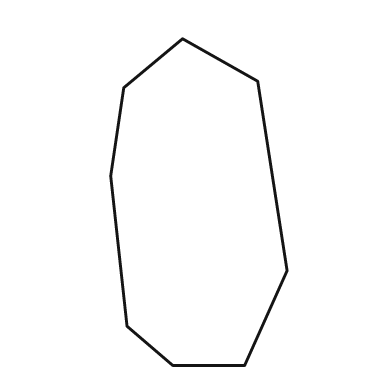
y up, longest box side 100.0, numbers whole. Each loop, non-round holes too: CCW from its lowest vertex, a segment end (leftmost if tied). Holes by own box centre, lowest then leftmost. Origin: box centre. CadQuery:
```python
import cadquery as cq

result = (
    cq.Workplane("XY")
    .moveTo(-8.0, -50.0)
    .lineTo(14.0, -50.0)
    .lineTo(27.0, -21.0)
    .lineTo(18.0, 37.0)
    .lineTo(-5.0, 50.0)
    .lineTo(-23.0, 35.0)
    .lineTo(-27.0, 8.0)
    .lineTo(-22.0, -38.0)
    .close()
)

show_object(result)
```